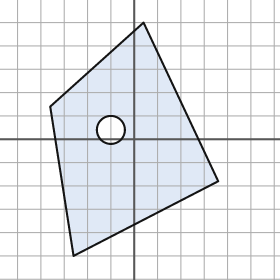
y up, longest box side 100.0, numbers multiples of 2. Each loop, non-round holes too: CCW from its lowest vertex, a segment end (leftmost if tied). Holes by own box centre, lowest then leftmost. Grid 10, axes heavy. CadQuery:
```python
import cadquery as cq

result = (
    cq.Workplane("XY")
    .moveTo(-26.0, -50.0)
    .lineTo(36.0, -18.0)
    .lineTo(4.0, 50.0)
    .lineTo(-36.0, 14.0)
    .close()
    .moveTo(-10.0, 4.0)
    .circle(6.0)
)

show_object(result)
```